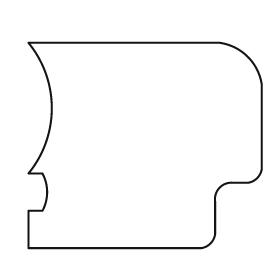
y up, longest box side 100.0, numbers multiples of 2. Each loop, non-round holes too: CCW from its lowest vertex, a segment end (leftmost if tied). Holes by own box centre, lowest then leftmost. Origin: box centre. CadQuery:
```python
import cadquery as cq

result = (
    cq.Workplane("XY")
    .moveTo(-50.0, -44.0)
    .lineTo(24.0, -44.0)
    .threePointArc((28.0, -42.0), (30.0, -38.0))
    .lineTo(30.0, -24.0)
    .threePointArc((32.0, -18.0), (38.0, -16.0))
    .lineTo(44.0, -16.0)
    .threePointArc((48.0, -14.0), (50.0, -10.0))
    .lineTo(50.0, 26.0)
    .threePointArc((44.0, 38.0), (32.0, 44.0))
    .lineTo(-50.0, 44.0)
    .threePointArc((-40.0, 16.0), (-50.0, -12.0))
    .lineTo(-44.0, -12.0)
    .threePointArc((-42.0, -20.0), (-44.0, -28.0))
    .lineTo(-50.0, -28.0)
    .close()
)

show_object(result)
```